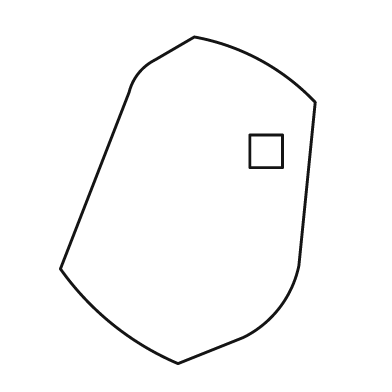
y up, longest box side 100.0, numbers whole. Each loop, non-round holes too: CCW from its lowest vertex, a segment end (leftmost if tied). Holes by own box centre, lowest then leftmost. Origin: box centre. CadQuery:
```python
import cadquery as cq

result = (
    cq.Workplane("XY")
    .moveTo(-3.0, -50.0)
    .lineTo(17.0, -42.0)
    .threePointArc((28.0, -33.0), (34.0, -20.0))
    .lineTo(39.0, 30.0)
    .threePointArc((22.0, 43.0), (2.0, 50.0))
    .lineTo(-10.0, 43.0)
    .threePointArc((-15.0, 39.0), (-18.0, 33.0))
    .lineTo(-39.0, -21.0)
    .threePointArc((-23.0, -38.0), (-3.0, -50.0))
    .close()
    .moveTo(19.0, 10.0)
    .lineTo(29.0, 10.0)
    .lineTo(29.0, 20.0)
    .lineTo(19.0, 20.0)
    .close()
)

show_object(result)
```